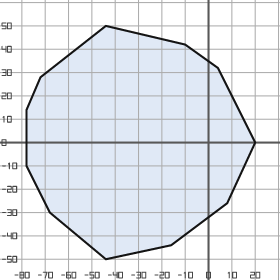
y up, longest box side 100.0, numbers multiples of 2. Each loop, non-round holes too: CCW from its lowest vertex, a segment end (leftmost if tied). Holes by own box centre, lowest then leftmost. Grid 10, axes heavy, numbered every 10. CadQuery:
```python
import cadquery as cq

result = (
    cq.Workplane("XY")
    .moveTo(-44.0, -50.0)
    .lineTo(-16.0, -44.0)
    .lineTo(8.0, -26.0)
    .lineTo(20.0, 0.0)
    .lineTo(4.0, 32.0)
    .lineTo(-10.0, 42.0)
    .lineTo(-44.0, 50.0)
    .lineTo(-72.0, 28.0)
    .lineTo(-78.0, 14.0)
    .lineTo(-78.0, -10.0)
    .lineTo(-68.0, -30.0)
    .close()
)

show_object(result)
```